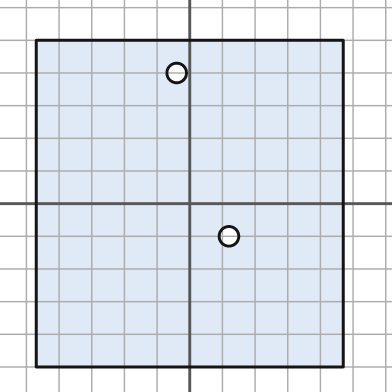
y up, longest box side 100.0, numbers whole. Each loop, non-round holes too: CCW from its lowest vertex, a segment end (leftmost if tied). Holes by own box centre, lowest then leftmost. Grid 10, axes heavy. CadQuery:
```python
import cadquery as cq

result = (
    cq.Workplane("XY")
    .moveTo(-47.0, -50.0)
    .lineTo(47.0, -50.0)
    .lineTo(47.0, 50.0)
    .lineTo(-47.0, 50.0)
    .close()
    .moveTo(12.0, -10.0)
    .circle(3.0)
    .moveTo(-4.0, 40.0)
    .circle(3.0)
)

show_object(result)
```